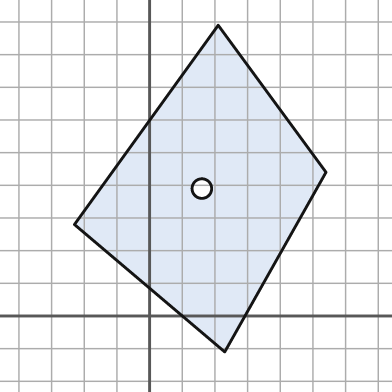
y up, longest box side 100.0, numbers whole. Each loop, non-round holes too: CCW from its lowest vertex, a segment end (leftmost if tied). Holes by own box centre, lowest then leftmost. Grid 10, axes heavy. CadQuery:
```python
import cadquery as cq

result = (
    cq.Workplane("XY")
    .moveTo(23.0, -11.0)
    .lineTo(54.0, 44.0)
    .lineTo(21.0, 89.0)
    .lineTo(-23.0, 28.0)
    .close()
    .moveTo(16.0, 39.0)
    .circle(3.0)
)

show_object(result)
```